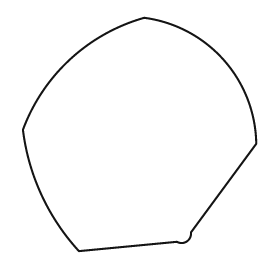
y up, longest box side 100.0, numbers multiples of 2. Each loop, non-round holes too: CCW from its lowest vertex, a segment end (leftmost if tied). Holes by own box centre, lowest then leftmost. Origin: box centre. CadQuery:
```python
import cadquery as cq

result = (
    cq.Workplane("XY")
    .moveTo(-26.0, -50.0)
    .lineTo(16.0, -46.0)
    .threePointArc((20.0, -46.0), (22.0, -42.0))
    .lineTo(50.0, -4.0)
    .threePointArc((36.0, 32.0), (2.0, 50.0))
    .threePointArc((-30.0, 32.0), (-50.0, 2.0))
    .threePointArc((-42.0, -26.0), (-26.0, -50.0))
    .close()
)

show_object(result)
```